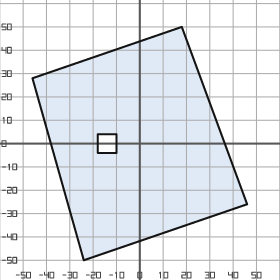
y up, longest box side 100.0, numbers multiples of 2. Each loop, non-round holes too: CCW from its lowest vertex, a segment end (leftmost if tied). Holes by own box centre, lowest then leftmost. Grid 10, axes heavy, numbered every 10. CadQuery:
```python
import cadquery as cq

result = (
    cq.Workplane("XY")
    .moveTo(-24.0, -50.0)
    .lineTo(46.0, -26.0)
    .lineTo(18.0, 50.0)
    .lineTo(-46.0, 28.0)
    .close()
    .moveTo(-18.0, -4.0)
    .lineTo(-10.0, -4.0)
    .lineTo(-10.0, 4.0)
    .lineTo(-18.0, 4.0)
    .close()
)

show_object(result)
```